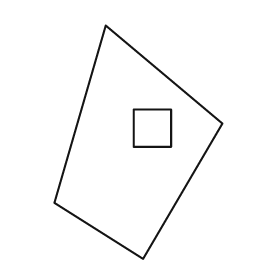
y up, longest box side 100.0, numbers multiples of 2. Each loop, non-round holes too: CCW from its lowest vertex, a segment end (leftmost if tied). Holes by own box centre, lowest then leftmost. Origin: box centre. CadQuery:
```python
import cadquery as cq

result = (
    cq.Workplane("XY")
    .moveTo(2.0, -50.0)
    .lineTo(36.0, 8.0)
    .lineTo(-14.0, 50.0)
    .lineTo(-36.0, -26.0)
    .close()
    .moveTo(-2.0, -2.0)
    .lineTo(14.0, -2.0)
    .lineTo(14.0, 14.0)
    .lineTo(-2.0, 14.0)
    .close()
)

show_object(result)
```